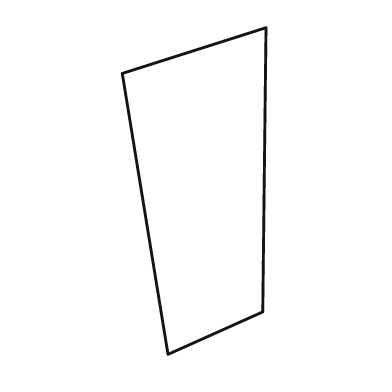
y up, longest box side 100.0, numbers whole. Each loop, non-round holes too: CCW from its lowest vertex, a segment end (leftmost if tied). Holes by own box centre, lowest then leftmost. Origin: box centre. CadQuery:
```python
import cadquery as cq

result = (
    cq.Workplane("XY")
    .moveTo(-8.0, -50.0)
    .lineTo(21.0, -37.0)
    .lineTo(22.0, 50.0)
    .lineTo(-22.0, 36.0)
    .close()
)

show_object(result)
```